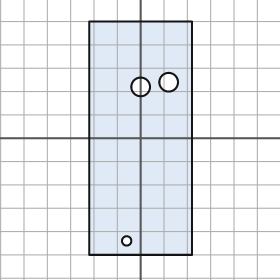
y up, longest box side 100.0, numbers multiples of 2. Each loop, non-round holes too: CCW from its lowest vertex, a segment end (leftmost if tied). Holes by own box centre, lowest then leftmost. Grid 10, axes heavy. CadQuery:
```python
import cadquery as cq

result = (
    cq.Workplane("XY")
    .moveTo(-22.0, -50.0)
    .lineTo(22.0, -50.0)
    .lineTo(22.0, 50.0)
    .lineTo(-22.0, 50.0)
    .close()
    .moveTo(-6.0, -44.0)
    .circle(2.0)
    .moveTo(0.0, 22.0)
    .circle(4.0)
    .moveTo(12.0, 24.0)
    .circle(4.0)
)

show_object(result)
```